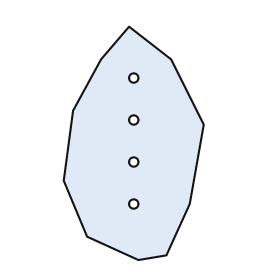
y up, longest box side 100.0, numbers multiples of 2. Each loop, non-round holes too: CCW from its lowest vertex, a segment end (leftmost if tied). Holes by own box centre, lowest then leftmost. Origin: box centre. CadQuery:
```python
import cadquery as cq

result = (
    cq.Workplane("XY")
    .moveTo(2.0, -50.0)
    .lineTo(14.0, -48.0)
    .lineTo(24.0, -26.0)
    .lineTo(30.0, 8.0)
    .lineTo(16.0, 36.0)
    .lineTo(-2.0, 50.0)
    .lineTo(-14.0, 36.0)
    .lineTo(-26.0, 14.0)
    .lineTo(-30.0, -16.0)
    .lineTo(-20.0, -40.0)
    .close()
    .moveTo(0.0, -26.0)
    .circle(2.0)
    .moveTo(0.0, -8.0)
    .circle(2.0)
    .moveTo(0.0, 10.0)
    .circle(2.0)
    .moveTo(0.0, 28.0)
    .circle(2.0)
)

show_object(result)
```